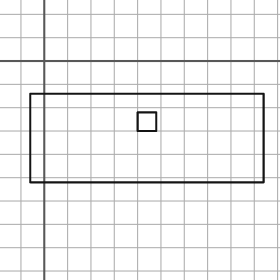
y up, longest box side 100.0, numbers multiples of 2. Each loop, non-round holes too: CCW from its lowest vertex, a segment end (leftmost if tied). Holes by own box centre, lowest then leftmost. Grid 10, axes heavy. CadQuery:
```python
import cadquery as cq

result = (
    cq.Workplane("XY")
    .moveTo(-6.0, -52.0)
    .lineTo(94.0, -52.0)
    .lineTo(94.0, -14.0)
    .lineTo(-6.0, -14.0)
    .close()
    .moveTo(40.0, -30.0)
    .lineTo(48.0, -30.0)
    .lineTo(48.0, -22.0)
    .lineTo(40.0, -22.0)
    .close()
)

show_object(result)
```